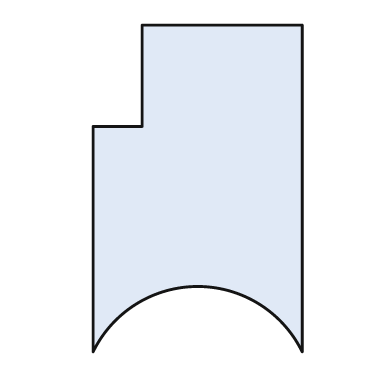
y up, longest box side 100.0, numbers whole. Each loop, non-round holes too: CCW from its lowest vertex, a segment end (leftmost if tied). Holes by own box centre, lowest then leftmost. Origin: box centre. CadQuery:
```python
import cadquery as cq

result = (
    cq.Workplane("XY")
    .moveTo(-32.0, -50.0)
    .threePointArc((0.0, -30.0), (32.0, -50.0))
    .lineTo(32.0, 50.0)
    .lineTo(-17.0, 50.0)
    .lineTo(-17.0, 19.0)
    .lineTo(-32.0, 19.0)
    .close()
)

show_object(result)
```